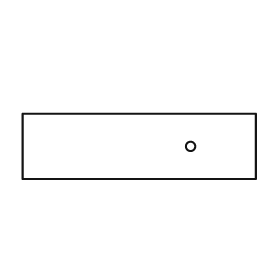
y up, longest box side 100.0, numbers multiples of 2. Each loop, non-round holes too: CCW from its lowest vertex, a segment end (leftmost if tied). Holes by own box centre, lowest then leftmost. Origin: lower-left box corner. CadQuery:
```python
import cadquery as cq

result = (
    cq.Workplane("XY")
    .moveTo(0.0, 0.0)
    .lineTo(100.0, 0.0)
    .lineTo(100.0, 28.0)
    .lineTo(0.0, 28.0)
    .close()
    .moveTo(72.0, 14.0)
    .circle(2.0)
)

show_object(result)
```